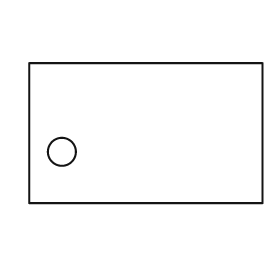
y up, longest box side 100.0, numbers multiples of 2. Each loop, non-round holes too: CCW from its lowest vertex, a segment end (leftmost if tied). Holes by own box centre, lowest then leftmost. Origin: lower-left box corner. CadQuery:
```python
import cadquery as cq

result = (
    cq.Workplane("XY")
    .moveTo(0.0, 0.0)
    .lineTo(100.0, 0.0)
    .lineTo(100.0, 60.0)
    .lineTo(0.0, 60.0)
    .close()
    .moveTo(14.0, 22.0)
    .circle(6.0)
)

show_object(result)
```